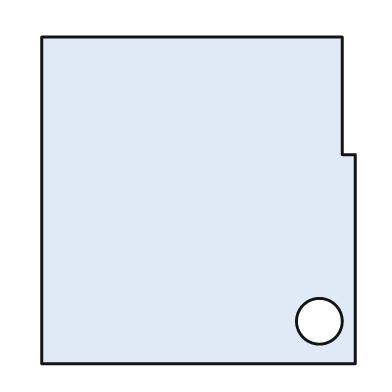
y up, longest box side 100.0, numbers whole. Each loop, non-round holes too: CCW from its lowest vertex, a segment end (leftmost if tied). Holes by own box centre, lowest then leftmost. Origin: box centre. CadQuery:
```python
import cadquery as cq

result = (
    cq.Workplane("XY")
    .moveTo(-48.0, -50.0)
    .lineTo(48.0, -50.0)
    .lineTo(48.0, 14.0)
    .lineTo(44.0, 14.0)
    .lineTo(44.0, 50.0)
    .lineTo(-48.0, 50.0)
    .close()
    .moveTo(37.0, -37.0)
    .circle(7.0)
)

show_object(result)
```